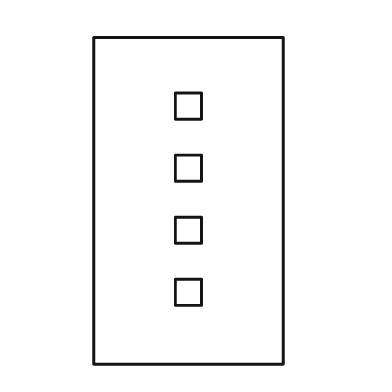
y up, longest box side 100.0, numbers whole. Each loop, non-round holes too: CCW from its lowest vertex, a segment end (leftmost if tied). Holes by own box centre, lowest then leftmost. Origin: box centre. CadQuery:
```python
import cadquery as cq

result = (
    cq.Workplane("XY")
    .moveTo(-29.0, -50.0)
    .lineTo(29.0, -50.0)
    .lineTo(29.0, 50.0)
    .lineTo(-29.0, 50.0)
    .close()
    .moveTo(-4.0, -32.0)
    .lineTo(4.0, -32.0)
    .lineTo(4.0, -24.0)
    .lineTo(-4.0, -24.0)
    .close()
    .moveTo(-4.0, -13.0)
    .lineTo(4.0, -13.0)
    .lineTo(4.0, -5.0)
    .lineTo(-4.0, -5.0)
    .close()
    .moveTo(-4.0, 6.0)
    .lineTo(4.0, 6.0)
    .lineTo(4.0, 14.0)
    .lineTo(-4.0, 14.0)
    .close()
    .moveTo(-4.0, 25.0)
    .lineTo(4.0, 25.0)
    .lineTo(4.0, 33.0)
    .lineTo(-4.0, 33.0)
    .close()
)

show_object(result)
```